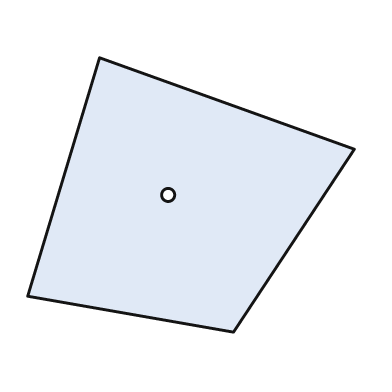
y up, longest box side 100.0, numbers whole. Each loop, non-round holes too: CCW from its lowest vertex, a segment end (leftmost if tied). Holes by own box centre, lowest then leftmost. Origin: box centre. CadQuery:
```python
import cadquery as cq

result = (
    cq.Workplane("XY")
    .moveTo(13.0, -42.0)
    .lineTo(50.0, 14.0)
    .lineTo(-28.0, 42.0)
    .lineTo(-50.0, -31.0)
    .close()
    .moveTo(-7.0, 0.0)
    .circle(2.0)
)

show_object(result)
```